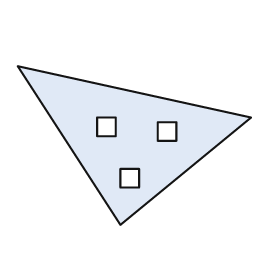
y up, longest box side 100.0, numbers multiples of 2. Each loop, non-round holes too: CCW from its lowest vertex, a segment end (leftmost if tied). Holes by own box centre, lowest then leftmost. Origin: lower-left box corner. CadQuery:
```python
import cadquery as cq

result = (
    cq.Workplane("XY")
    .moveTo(44.0, 0.0)
    .lineTo(100.0, 46.0)
    .lineTo(0.0, 68.0)
    .close()
    .moveTo(44.0, 16.0)
    .lineTo(52.0, 16.0)
    .lineTo(52.0, 24.0)
    .lineTo(44.0, 24.0)
    .close()
    .moveTo(60.0, 36.0)
    .lineTo(68.0, 36.0)
    .lineTo(68.0, 44.0)
    .lineTo(60.0, 44.0)
    .close()
    .moveTo(34.0, 38.0)
    .lineTo(42.0, 38.0)
    .lineTo(42.0, 46.0)
    .lineTo(34.0, 46.0)
    .close()
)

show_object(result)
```